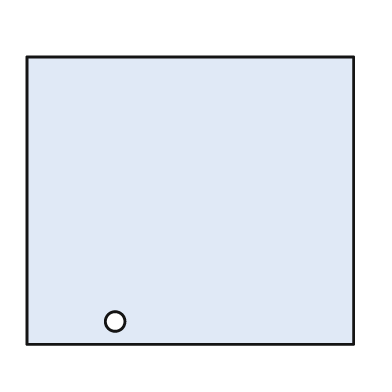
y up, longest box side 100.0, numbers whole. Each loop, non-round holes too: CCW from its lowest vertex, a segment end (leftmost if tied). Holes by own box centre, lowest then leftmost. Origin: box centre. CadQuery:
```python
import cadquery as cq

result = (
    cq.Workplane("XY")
    .moveTo(-50.0, -44.0)
    .lineTo(50.0, -44.0)
    .lineTo(50.0, 44.0)
    .lineTo(-50.0, 44.0)
    .close()
    .moveTo(-23.0, -37.0)
    .circle(3.0)
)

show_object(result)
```